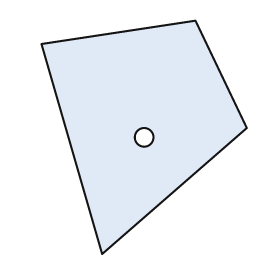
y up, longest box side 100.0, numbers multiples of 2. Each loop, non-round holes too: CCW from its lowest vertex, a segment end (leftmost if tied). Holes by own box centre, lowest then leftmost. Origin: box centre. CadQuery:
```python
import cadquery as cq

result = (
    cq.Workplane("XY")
    .moveTo(-18.0, -50.0)
    .lineTo(44.0, 4.0)
    .lineTo(22.0, 50.0)
    .lineTo(-44.0, 40.0)
    .close()
    .moveTo(0.0, 0.0)
    .circle(4.0)
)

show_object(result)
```